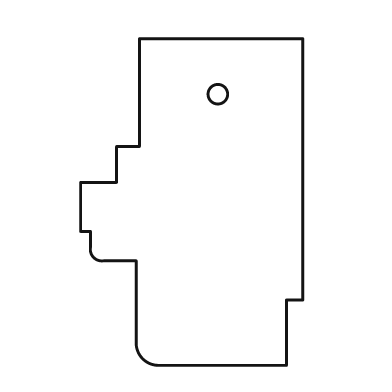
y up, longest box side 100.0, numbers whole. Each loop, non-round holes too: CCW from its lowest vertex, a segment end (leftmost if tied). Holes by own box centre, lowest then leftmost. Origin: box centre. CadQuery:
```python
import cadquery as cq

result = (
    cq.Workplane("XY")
    .moveTo(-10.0, -50.0)
    .lineTo(29.0, -50.0)
    .lineTo(29.0, -30.0)
    .lineTo(34.0, -30.0)
    .lineTo(34.0, 50.0)
    .lineTo(-16.0, 50.0)
    .lineTo(-16.0, 17.0)
    .lineTo(-23.0, 17.0)
    .lineTo(-23.0, 6.0)
    .lineTo(-34.0, 6.0)
    .lineTo(-34.0, -9.0)
    .lineTo(-31.0, -9.0)
    .lineTo(-31.0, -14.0)
    .threePointArc((-30.0, -17.0), (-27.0, -18.0))
    .lineTo(-17.0, -18.0)
    .lineTo(-17.0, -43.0)
    .threePointArc((-15.0, -48.0), (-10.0, -50.0))
    .close()
    .moveTo(8.0, 33.0)
    .circle(3.0)
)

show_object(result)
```